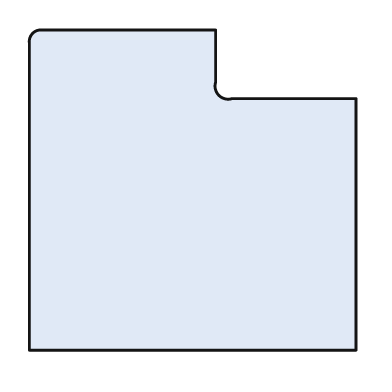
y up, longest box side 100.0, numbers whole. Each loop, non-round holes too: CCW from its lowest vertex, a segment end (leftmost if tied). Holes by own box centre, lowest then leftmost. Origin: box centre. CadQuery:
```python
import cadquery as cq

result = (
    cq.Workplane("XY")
    .moveTo(-50.0, -49.0)
    .lineTo(50.0, -49.0)
    .lineTo(50.0, 28.0)
    .lineTo(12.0, 28.0)
    .threePointArc((8.0, 29.0), (7.0, 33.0))
    .lineTo(7.0, 49.0)
    .lineTo(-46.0, 49.0)
    .threePointArc((-49.0, 48.0), (-50.0, 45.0))
    .close()
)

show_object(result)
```